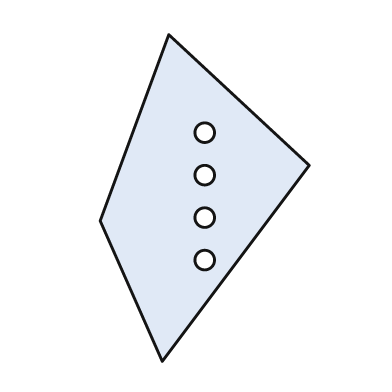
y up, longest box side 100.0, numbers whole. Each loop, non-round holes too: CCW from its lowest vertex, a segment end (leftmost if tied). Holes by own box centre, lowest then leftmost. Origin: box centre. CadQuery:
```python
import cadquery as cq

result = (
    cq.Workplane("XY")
    .moveTo(-13.0, -50.0)
    .lineTo(32.0, 10.0)
    .lineTo(-11.0, 50.0)
    .lineTo(-32.0, -7.0)
    .close()
    .moveTo(0.0, -19.0)
    .circle(3.0)
    .moveTo(0.0, -6.0)
    .circle(3.0)
    .moveTo(0.0, 7.0)
    .circle(3.0)
    .moveTo(0.0, 20.0)
    .circle(3.0)
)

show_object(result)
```